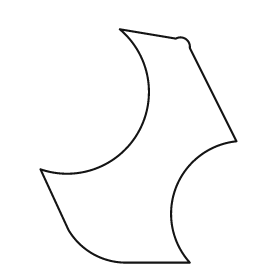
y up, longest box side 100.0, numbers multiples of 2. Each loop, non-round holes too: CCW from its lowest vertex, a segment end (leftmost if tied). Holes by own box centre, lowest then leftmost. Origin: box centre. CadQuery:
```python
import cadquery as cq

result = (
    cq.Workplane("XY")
    .moveTo(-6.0, -50.0)
    .lineTo(22.0, -50.0)
    .threePointArc((16.0, -18.0), (42.0, 2.0))
    .lineTo(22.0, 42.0)
    .threePointArc((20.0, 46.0), (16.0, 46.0))
    .lineTo(-8.0, 50.0)
    .threePointArc((0.0, 6.0), (-42.0, -10.0))
    .lineTo(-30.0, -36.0)
    .threePointArc((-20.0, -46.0), (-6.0, -50.0))
    .close()
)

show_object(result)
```